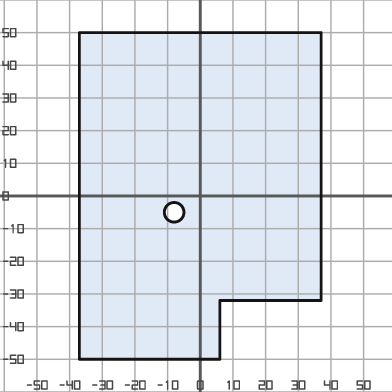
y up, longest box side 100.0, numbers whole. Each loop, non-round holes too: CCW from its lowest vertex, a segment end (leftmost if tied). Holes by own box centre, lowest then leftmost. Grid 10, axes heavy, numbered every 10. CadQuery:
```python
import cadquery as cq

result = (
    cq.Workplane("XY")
    .moveTo(-37.0, -50.0)
    .lineTo(6.0, -50.0)
    .lineTo(6.0, -32.0)
    .lineTo(37.0, -32.0)
    .lineTo(37.0, 50.0)
    .lineTo(-37.0, 50.0)
    .close()
    .moveTo(-8.0, -5.0)
    .circle(3.0)
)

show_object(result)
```